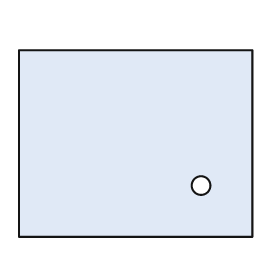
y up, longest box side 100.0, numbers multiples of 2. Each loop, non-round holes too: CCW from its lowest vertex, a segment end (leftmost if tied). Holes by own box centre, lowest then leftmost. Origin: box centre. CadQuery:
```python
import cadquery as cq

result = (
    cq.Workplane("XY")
    .moveTo(-50.0, -40.0)
    .lineTo(50.0, -40.0)
    .lineTo(50.0, 40.0)
    .lineTo(-50.0, 40.0)
    .close()
    .moveTo(28.0, -18.0)
    .circle(4.0)
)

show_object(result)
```